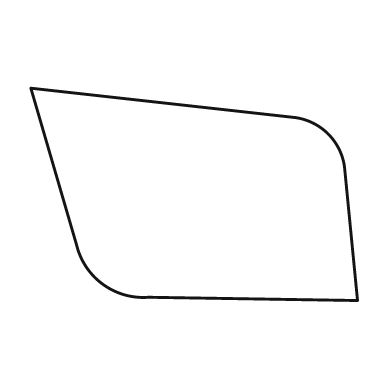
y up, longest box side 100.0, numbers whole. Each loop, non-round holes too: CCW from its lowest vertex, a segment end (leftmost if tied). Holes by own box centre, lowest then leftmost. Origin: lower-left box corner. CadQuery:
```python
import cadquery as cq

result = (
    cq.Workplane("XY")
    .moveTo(100.0, 0.0)
    .lineTo(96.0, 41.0)
    .threePointArc((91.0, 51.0), (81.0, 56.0))
    .lineTo(0.0, 65.0)
    .lineTo(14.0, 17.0)
    .threePointArc((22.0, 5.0), (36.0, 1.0))
    .close()
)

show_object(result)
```